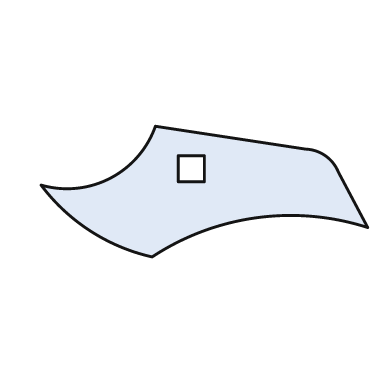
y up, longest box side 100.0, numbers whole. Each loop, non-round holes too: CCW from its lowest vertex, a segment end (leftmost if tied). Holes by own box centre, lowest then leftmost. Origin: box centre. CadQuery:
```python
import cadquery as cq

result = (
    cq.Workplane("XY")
    .moveTo(-16.0, -20.0)
    .threePointArc((16.0, -8.0), (50.0, -11.0))
    .lineTo(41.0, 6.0)
    .threePointArc((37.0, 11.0), (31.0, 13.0))
    .lineTo(-15.0, 20.0)
    .threePointArc((-29.0, 4.0), (-50.0, 2.0))
    .threePointArc((-35.0, -12.0), (-16.0, -20.0))
    .close()
    .moveTo(-8.0, 3.0)
    .lineTo(0.0, 3.0)
    .lineTo(0.0, 11.0)
    .lineTo(-8.0, 11.0)
    .close()
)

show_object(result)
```